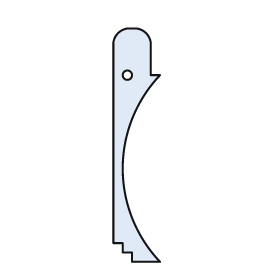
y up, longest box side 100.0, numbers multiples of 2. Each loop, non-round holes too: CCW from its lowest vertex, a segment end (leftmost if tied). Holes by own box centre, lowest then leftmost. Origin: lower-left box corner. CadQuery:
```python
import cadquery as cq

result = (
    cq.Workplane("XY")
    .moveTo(8.0, 0.0)
    .lineTo(20.0, 0.0)
    .threePointArc((4.0, 40.0), (20.0, 80.0))
    .lineTo(16.0, 80.0)
    .lineTo(16.0, 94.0)
    .threePointArc((14.0, 98.0), (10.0, 100.0))
    .lineTo(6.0, 100.0)
    .threePointArc((2.0, 98.0), (0.0, 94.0))
    .lineTo(0.0, 8.0)
    .lineTo(4.0, 8.0)
    .lineTo(4.0, 4.0)
    .lineTo(8.0, 4.0)
    .close()
    .moveTo(6.0, 80.0)
    .circle(2.0)
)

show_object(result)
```